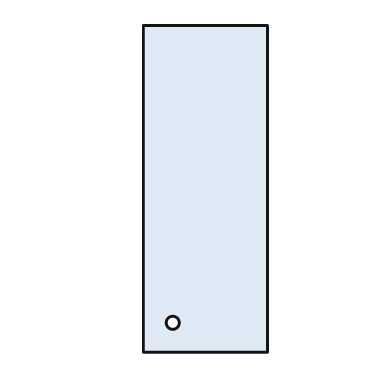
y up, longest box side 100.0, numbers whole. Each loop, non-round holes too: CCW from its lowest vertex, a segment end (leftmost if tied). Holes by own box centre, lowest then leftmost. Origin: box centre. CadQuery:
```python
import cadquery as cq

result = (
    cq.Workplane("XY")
    .moveTo(-19.0, -50.0)
    .lineTo(19.0, -50.0)
    .lineTo(19.0, 50.0)
    .lineTo(-19.0, 50.0)
    .close()
    .moveTo(-10.0, -41.0)
    .circle(2.0)
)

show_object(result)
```